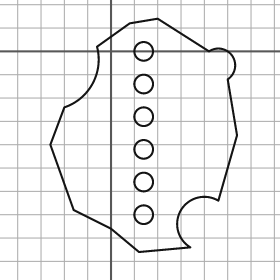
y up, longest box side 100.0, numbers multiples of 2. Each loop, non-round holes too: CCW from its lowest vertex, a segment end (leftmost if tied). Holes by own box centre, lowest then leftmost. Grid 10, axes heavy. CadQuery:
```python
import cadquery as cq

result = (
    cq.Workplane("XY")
    .moveTo(12.0, -86.0)
    .lineTo(34.0, -84.0)
    .threePointArc((30.0, -68.0), (46.0, -64.0))
    .lineTo(54.0, -36.0)
    .lineTo(50.0, -12.0)
    .threePointArc((52.0, -2.0), (42.0, 0.0))
    .lineTo(20.0, 14.0)
    .lineTo(8.0, 12.0)
    .lineTo(-6.0, 2.0)
    .threePointArc((-8.0, -14.0), (-20.0, -24.0))
    .lineTo(-26.0, -40.0)
    .lineTo(-16.0, -68.0)
    .lineTo(0.0, -76.0)
    .close()
    .moveTo(14.0, -70.0)
    .circle(4.0)
    .moveTo(14.0, -56.0)
    .circle(4.0)
    .moveTo(14.0, -42.0)
    .circle(4.0)
    .moveTo(14.0, -28.0)
    .circle(4.0)
    .moveTo(14.0, -14.0)
    .circle(4.0)
    .moveTo(14.0, 0.0)
    .circle(4.0)
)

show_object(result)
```